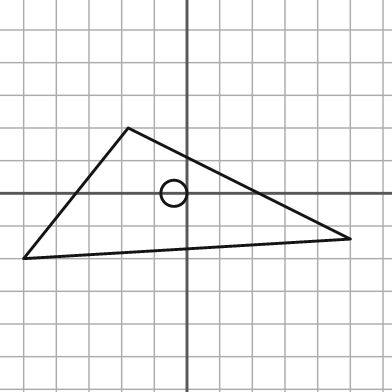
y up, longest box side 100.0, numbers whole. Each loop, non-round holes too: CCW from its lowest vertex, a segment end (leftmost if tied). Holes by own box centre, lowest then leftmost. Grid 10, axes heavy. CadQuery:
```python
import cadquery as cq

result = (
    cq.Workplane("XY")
    .moveTo(-50.0, -20.0)
    .lineTo(50.0, -14.0)
    .lineTo(-18.0, 20.0)
    .close()
    .moveTo(-4.0, 0.0)
    .circle(4.0)
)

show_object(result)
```